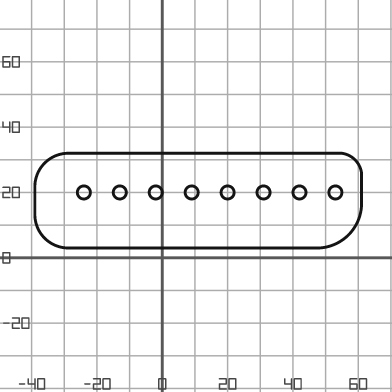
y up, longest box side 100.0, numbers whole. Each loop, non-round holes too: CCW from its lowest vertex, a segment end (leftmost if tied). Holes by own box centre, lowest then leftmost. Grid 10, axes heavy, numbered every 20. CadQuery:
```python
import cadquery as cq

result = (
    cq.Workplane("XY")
    .moveTo(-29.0, 3.0)
    .lineTo(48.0, 3.0)
    .threePointArc((57.0, 7.0), (61.0, 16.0))
    .lineTo(61.0, 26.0)
    .threePointArc((59.0, 30.0), (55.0, 32.0))
    .lineTo(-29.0, 32.0)
    .threePointArc((-36.0, 29.0), (-39.0, 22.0))
    .lineTo(-39.0, 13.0)
    .threePointArc((-36.0, 6.0), (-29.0, 3.0))
    .close()
    .moveTo(-24.0, 20.0)
    .circle(2.0)
    .moveTo(-13.0, 20.0)
    .circle(2.0)
    .moveTo(-2.0, 20.0)
    .circle(2.0)
    .moveTo(9.0, 20.0)
    .circle(2.0)
    .moveTo(20.0, 20.0)
    .circle(2.0)
    .moveTo(31.0, 20.0)
    .circle(2.0)
    .moveTo(42.0, 20.0)
    .circle(2.0)
    .moveTo(53.0, 20.0)
    .circle(2.0)
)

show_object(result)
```